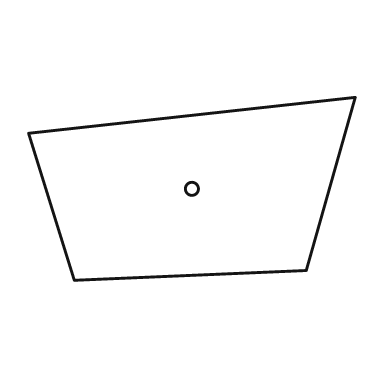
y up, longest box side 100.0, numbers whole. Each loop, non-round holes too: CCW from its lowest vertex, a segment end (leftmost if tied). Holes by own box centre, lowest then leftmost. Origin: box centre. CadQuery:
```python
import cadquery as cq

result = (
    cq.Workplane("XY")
    .moveTo(-36.0, -28.0)
    .lineTo(35.0, -25.0)
    .lineTo(50.0, 28.0)
    .lineTo(-50.0, 17.0)
    .close()
    .moveTo(0.0, 0.0)
    .circle(2.0)
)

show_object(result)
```